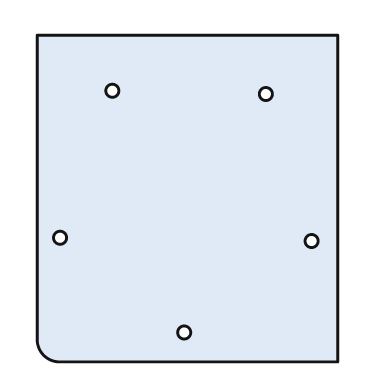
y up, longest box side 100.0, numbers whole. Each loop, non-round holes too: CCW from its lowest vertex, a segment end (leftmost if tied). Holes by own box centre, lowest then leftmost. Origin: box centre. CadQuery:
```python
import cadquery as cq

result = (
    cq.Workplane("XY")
    .moveTo(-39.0, -50.0)
    .lineTo(46.0, -50.0)
    .lineTo(46.0, 50.0)
    .lineTo(-46.0, 50.0)
    .lineTo(-46.0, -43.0)
    .threePointArc((-44.0, -48.0), (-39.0, -50.0))
    .close()
    .moveTo(-1.0, -41.0)
    .circle(2.0)
    .moveTo(38.0, -13.0)
    .circle(2.0)
    .moveTo(-39.0, -12.0)
    .circle(2.0)
    .moveTo(24.0, 32.0)
    .circle(2.0)
    .moveTo(-23.0, 33.0)
    .circle(2.0)
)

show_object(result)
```